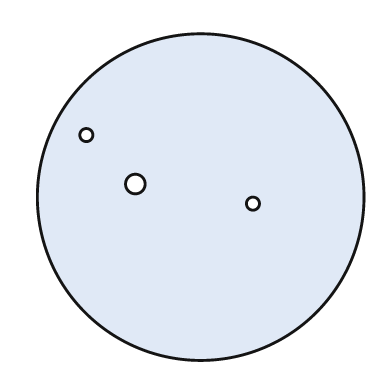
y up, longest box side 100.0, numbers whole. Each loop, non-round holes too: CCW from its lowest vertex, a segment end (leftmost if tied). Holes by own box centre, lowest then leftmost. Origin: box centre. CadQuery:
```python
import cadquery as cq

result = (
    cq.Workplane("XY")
    .moveTo(0.0, 0.0)
    .circle(50.0)
    .moveTo(16.0, -2.0)
    .circle(2.0)
    .moveTo(-20.0, 4.0)
    .circle(3.0)
    .moveTo(-35.0, 19.0)
    .circle(2.0)
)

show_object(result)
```